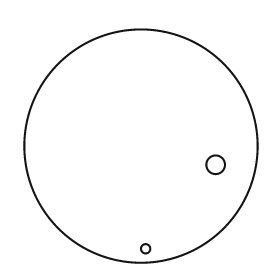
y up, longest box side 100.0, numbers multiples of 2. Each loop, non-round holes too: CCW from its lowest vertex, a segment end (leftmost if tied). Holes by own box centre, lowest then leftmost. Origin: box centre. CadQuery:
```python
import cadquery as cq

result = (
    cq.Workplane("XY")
    .moveTo(0.0, 0.0)
    .circle(50.0)
    .moveTo(2.0, -44.0)
    .circle(2.0)
    .moveTo(32.0, -8.0)
    .circle(4.0)
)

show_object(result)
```